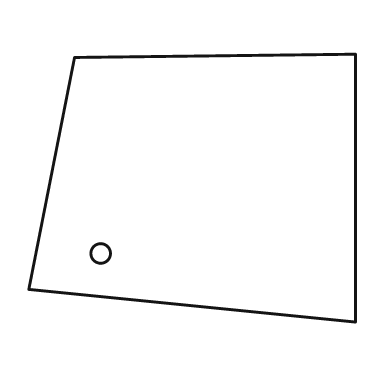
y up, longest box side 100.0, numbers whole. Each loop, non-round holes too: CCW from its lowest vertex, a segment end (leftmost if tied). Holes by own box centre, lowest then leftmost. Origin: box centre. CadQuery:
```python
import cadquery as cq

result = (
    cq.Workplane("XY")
    .moveTo(50.0, -41.0)
    .lineTo(50.0, 41.0)
    .lineTo(-36.0, 40.0)
    .lineTo(-50.0, -31.0)
    .close()
    .moveTo(-28.0, -20.0)
    .circle(3.0)
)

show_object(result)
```